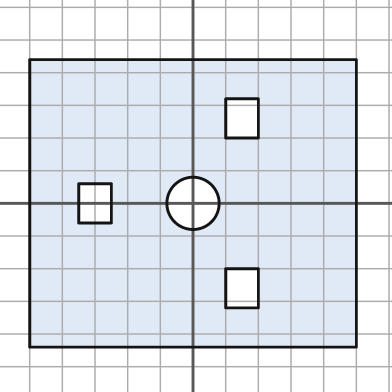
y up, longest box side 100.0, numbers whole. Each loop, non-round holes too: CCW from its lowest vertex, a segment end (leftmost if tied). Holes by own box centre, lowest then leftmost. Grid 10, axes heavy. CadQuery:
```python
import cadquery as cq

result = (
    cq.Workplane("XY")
    .moveTo(-50.0, -44.0)
    .lineTo(50.0, -44.0)
    .lineTo(50.0, 44.0)
    .lineTo(-50.0, 44.0)
    .close()
    .moveTo(10.0, -32.0)
    .lineTo(20.0, -32.0)
    .lineTo(20.0, -20.0)
    .lineTo(10.0, -20.0)
    .close()
    .moveTo(-35.0, -6.0)
    .lineTo(-25.0, -6.0)
    .lineTo(-25.0, 6.0)
    .lineTo(-35.0, 6.0)
    .close()
    .moveTo(0.0, 0.0)
    .circle(8.0)
    .moveTo(10.0, 20.0)
    .lineTo(20.0, 20.0)
    .lineTo(20.0, 32.0)
    .lineTo(10.0, 32.0)
    .close()
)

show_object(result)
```